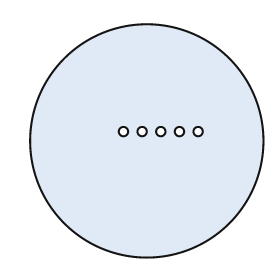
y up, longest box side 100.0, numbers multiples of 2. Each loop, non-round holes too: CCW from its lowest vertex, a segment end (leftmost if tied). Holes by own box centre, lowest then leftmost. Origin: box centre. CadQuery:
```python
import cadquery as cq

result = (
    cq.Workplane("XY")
    .moveTo(0.0, 0.0)
    .circle(50.0)
    .moveTo(-10.0, 4.0)
    .circle(2.0)
    .moveTo(-2.0, 4.0)
    .circle(2.0)
    .moveTo(6.0, 4.0)
    .circle(2.0)
    .moveTo(14.0, 4.0)
    .circle(2.0)
    .moveTo(22.0, 4.0)
    .circle(2.0)
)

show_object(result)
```